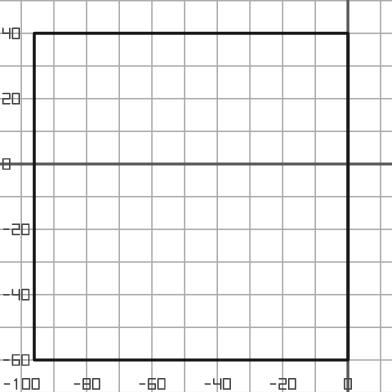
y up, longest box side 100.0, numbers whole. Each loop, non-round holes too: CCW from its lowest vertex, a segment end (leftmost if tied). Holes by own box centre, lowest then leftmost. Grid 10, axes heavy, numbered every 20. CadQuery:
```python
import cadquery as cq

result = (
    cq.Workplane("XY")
    .moveTo(-96.0, -60.0)
    .lineTo(0.0, -60.0)
    .lineTo(0.0, 40.0)
    .lineTo(-96.0, 40.0)
    .close()
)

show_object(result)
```